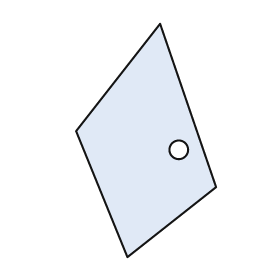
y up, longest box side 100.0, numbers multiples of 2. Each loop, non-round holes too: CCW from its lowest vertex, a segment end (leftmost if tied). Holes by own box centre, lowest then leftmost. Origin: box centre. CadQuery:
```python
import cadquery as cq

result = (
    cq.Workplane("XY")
    .moveTo(-8.0, -50.0)
    .lineTo(30.0, -20.0)
    .lineTo(6.0, 50.0)
    .lineTo(-30.0, 4.0)
    .close()
    .moveTo(14.0, -4.0)
    .circle(4.0)
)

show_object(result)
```